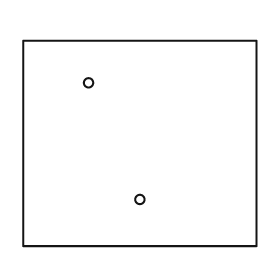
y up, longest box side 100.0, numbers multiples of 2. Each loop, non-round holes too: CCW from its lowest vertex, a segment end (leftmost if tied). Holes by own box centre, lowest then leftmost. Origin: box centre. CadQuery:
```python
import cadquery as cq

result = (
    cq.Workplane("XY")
    .moveTo(-50.0, -44.0)
    .lineTo(50.0, -44.0)
    .lineTo(50.0, 44.0)
    .lineTo(-50.0, 44.0)
    .close()
    .moveTo(0.0, -24.0)
    .circle(2.0)
    .moveTo(-22.0, 26.0)
    .circle(2.0)
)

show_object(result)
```